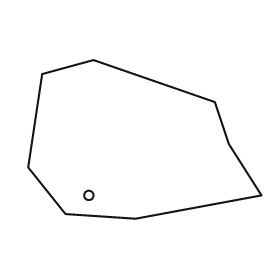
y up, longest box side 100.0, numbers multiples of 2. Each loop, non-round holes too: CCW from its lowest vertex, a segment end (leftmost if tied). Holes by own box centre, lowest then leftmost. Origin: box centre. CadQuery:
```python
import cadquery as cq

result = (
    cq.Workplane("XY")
    .moveTo(-4.0, -34.0)
    .lineTo(50.0, -24.0)
    .lineTo(36.0, -2.0)
    .lineTo(30.0, 16.0)
    .lineTo(-22.0, 34.0)
    .lineTo(-44.0, 28.0)
    .lineTo(-50.0, -12.0)
    .lineTo(-34.0, -32.0)
    .close()
    .moveTo(-24.0, -24.0)
    .circle(2.0)
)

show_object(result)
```